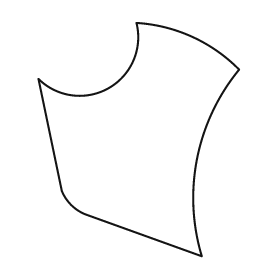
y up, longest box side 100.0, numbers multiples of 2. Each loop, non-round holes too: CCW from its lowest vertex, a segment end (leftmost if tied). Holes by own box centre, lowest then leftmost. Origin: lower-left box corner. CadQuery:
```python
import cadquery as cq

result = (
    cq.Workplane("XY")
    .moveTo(70.0, 0.0)
    .threePointArc((68.0, 42.0), (86.0, 80.0))
    .threePointArc((66.0, 94.0), (42.0, 100.0))
    .threePointArc((30.0, 72.0), (0.0, 76.0))
    .lineTo(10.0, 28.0)
    .threePointArc((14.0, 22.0), (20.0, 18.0))
    .close()
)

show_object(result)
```